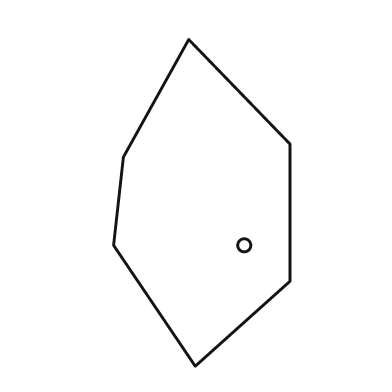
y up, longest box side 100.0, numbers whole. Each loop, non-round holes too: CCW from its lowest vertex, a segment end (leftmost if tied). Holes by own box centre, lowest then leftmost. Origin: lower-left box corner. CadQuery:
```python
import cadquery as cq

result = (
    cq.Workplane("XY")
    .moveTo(25.0, 0.0)
    .lineTo(54.0, 26.0)
    .lineTo(54.0, 68.0)
    .lineTo(23.0, 100.0)
    .lineTo(3.0, 64.0)
    .lineTo(0.0, 37.0)
    .close()
    .moveTo(40.0, 37.0)
    .circle(2.0)
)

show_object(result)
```